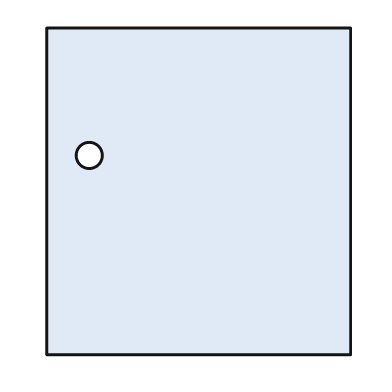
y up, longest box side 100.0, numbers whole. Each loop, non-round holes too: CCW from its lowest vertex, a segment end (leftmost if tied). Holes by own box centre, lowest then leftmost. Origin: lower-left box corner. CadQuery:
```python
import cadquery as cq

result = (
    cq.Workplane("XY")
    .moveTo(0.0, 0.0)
    .lineTo(93.0, 0.0)
    .lineTo(93.0, 100.0)
    .lineTo(0.0, 100.0)
    .close()
    .moveTo(13.0, 61.0)
    .circle(4.0)
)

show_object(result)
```